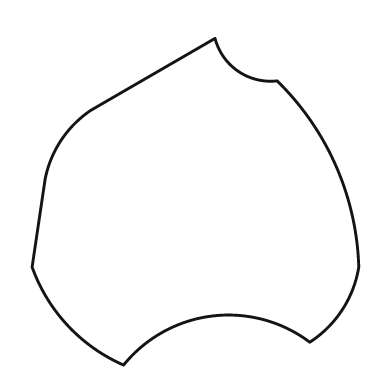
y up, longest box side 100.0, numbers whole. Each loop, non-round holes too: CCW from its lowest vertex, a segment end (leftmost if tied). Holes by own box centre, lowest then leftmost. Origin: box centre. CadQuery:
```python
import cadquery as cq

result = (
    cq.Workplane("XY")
    .moveTo(-22.0, -50.0)
    .threePointArc((5.0, -35.0), (35.0, -43.0))
    .threePointArc((45.0, -33.0), (50.0, -20.0))
    .threePointArc((43.0, 11.0), (25.0, 37.0))
    .threePointArc((13.0, 40.0), (6.0, 50.0))
    .lineTo(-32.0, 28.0)
    .threePointArc((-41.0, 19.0), (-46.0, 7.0))
    .lineTo(-50.0, -20.0)
    .threePointArc((-39.0, -38.0), (-22.0, -50.0))
    .close()
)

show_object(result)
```